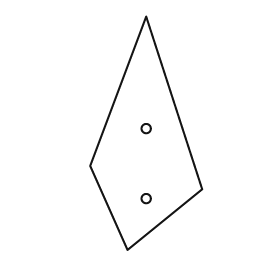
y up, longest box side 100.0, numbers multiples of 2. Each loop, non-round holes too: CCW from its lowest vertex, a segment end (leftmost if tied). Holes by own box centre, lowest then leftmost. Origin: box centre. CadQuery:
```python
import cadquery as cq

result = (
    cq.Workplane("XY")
    .moveTo(-8.0, -50.0)
    .lineTo(24.0, -24.0)
    .lineTo(0.0, 50.0)
    .lineTo(-24.0, -14.0)
    .close()
    .moveTo(0.0, -28.0)
    .circle(2.0)
    .moveTo(0.0, 2.0)
    .circle(2.0)
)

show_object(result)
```